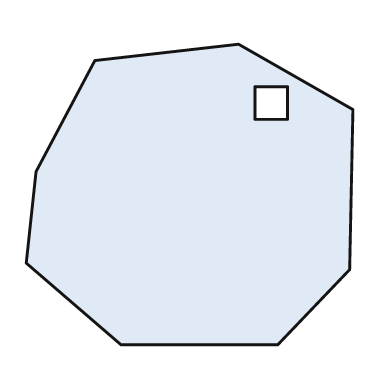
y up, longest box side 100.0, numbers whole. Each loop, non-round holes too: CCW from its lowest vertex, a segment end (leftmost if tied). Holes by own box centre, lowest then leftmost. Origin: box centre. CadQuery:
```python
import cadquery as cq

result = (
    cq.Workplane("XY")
    .moveTo(-21.0, -46.0)
    .lineTo(27.0, -46.0)
    .lineTo(49.0, -23.0)
    .lineTo(50.0, 26.0)
    .lineTo(15.0, 46.0)
    .lineTo(-29.0, 41.0)
    .lineTo(-47.0, 7.0)
    .lineTo(-50.0, -21.0)
    .close()
    .moveTo(20.0, 23.0)
    .lineTo(30.0, 23.0)
    .lineTo(30.0, 33.0)
    .lineTo(20.0, 33.0)
    .close()
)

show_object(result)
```